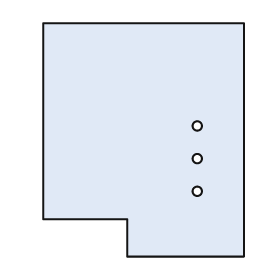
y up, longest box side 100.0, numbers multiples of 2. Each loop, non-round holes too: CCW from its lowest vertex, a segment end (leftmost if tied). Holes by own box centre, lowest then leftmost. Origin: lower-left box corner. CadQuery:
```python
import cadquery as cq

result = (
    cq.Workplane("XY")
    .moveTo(36.0, 0.0)
    .lineTo(86.0, 0.0)
    .lineTo(86.0, 100.0)
    .lineTo(0.0, 100.0)
    .lineTo(0.0, 16.0)
    .lineTo(36.0, 16.0)
    .close()
    .moveTo(66.0, 28.0)
    .circle(2.0)
    .moveTo(66.0, 42.0)
    .circle(2.0)
    .moveTo(66.0, 56.0)
    .circle(2.0)
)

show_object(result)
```